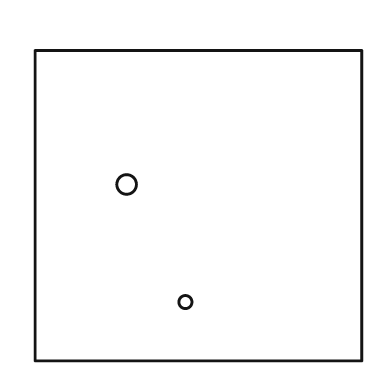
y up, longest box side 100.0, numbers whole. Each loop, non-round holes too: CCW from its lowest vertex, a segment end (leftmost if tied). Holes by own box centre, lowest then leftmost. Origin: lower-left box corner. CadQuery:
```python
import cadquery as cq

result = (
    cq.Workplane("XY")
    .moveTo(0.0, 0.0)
    .lineTo(100.0, 0.0)
    .lineTo(100.0, 95.0)
    .lineTo(0.0, 95.0)
    .close()
    .moveTo(46.0, 18.0)
    .circle(2.0)
    .moveTo(28.0, 54.0)
    .circle(3.0)
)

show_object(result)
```